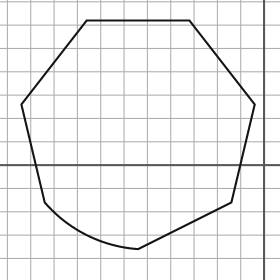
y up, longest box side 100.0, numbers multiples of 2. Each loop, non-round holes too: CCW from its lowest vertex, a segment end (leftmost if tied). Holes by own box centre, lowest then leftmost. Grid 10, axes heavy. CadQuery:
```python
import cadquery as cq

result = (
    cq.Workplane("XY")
    .moveTo(-54.0, -36.0)
    .lineTo(-14.0, -16.0)
    .lineTo(-4.0, 26.0)
    .lineTo(-32.0, 62.0)
    .lineTo(-76.0, 62.0)
    .lineTo(-104.0, 26.0)
    .lineTo(-94.0, -16.0)
    .threePointArc((-76.0, -30.0), (-54.0, -36.0))
    .close()
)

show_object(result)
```